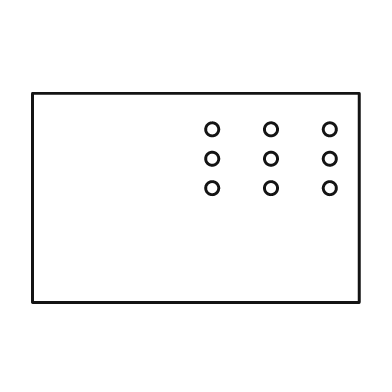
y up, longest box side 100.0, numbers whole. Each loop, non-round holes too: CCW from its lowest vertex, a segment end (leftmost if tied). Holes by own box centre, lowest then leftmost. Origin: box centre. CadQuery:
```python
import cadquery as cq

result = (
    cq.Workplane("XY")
    .moveTo(-50.0, -32.0)
    .lineTo(50.0, -32.0)
    .lineTo(50.0, 32.0)
    .lineTo(-50.0, 32.0)
    .close()
    .moveTo(5.0, 3.0)
    .circle(2.0)
    .moveTo(23.0, 3.0)
    .circle(2.0)
    .moveTo(41.0, 3.0)
    .circle(2.0)
    .moveTo(5.0, 12.0)
    .circle(2.0)
    .moveTo(23.0, 12.0)
    .circle(2.0)
    .moveTo(41.0, 12.0)
    .circle(2.0)
    .moveTo(5.0, 21.0)
    .circle(2.0)
    .moveTo(23.0, 21.0)
    .circle(2.0)
    .moveTo(41.0, 21.0)
    .circle(2.0)
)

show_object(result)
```